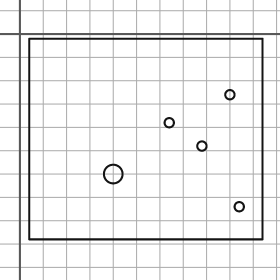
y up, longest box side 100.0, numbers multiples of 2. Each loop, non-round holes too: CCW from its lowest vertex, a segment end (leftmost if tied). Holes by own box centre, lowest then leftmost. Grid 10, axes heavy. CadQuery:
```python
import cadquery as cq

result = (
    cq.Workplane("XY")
    .moveTo(4.0, -88.0)
    .lineTo(104.0, -88.0)
    .lineTo(104.0, -2.0)
    .lineTo(4.0, -2.0)
    .close()
    .moveTo(94.0, -74.0)
    .circle(2.0)
    .moveTo(40.0, -60.0)
    .circle(4.0)
    .moveTo(78.0, -48.0)
    .circle(2.0)
    .moveTo(64.0, -38.0)
    .circle(2.0)
    .moveTo(90.0, -26.0)
    .circle(2.0)
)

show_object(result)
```